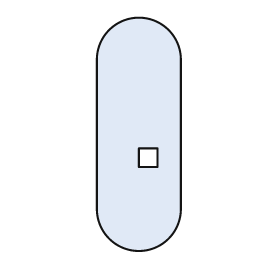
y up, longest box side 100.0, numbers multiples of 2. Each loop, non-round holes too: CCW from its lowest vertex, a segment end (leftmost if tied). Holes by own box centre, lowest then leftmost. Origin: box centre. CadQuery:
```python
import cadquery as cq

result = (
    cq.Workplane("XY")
    .moveTo(-18.0, -32.0)
    .threePointArc((0.0, -50.0), (18.0, -32.0))
    .lineTo(18.0, 32.0)
    .threePointArc((0.0, 50.0), (-18.0, 32.0))
    .close()
    .moveTo(0.0, -14.0)
    .lineTo(8.0, -14.0)
    .lineTo(8.0, -6.0)
    .lineTo(0.0, -6.0)
    .close()
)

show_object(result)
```